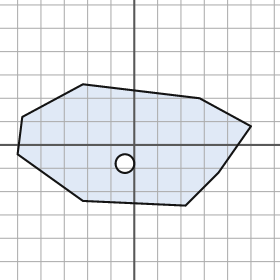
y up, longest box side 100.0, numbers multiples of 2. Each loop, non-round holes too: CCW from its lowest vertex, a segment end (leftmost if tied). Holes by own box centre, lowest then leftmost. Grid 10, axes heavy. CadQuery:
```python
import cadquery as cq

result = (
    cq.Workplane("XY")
    .moveTo(22.0, -26.0)
    .lineTo(36.0, -12.0)
    .lineTo(50.0, 8.0)
    .lineTo(28.0, 20.0)
    .lineTo(-22.0, 26.0)
    .lineTo(-48.0, 12.0)
    .lineTo(-50.0, -4.0)
    .lineTo(-22.0, -24.0)
    .close()
    .moveTo(-4.0, -8.0)
    .circle(4.0)
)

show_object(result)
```